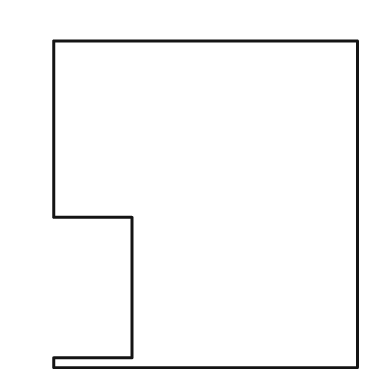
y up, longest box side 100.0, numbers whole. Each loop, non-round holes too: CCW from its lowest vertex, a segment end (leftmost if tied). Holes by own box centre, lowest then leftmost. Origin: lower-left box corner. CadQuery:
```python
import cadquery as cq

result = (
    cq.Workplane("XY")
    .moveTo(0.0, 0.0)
    .lineTo(93.0, 0.0)
    .lineTo(93.0, 100.0)
    .lineTo(0.0, 100.0)
    .lineTo(0.0, 46.0)
    .lineTo(24.0, 46.0)
    .lineTo(24.0, 3.0)
    .lineTo(0.0, 3.0)
    .close()
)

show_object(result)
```